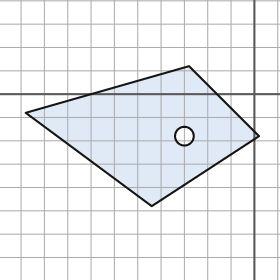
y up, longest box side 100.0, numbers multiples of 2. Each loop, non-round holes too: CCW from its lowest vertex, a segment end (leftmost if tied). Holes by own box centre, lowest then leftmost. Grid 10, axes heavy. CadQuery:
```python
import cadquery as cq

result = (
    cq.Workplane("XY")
    .moveTo(-44.0, -48.0)
    .lineTo(2.0, -18.0)
    .lineTo(-28.0, 12.0)
    .lineTo(-98.0, -8.0)
    .close()
    .moveTo(-30.0, -18.0)
    .circle(4.0)
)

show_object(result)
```